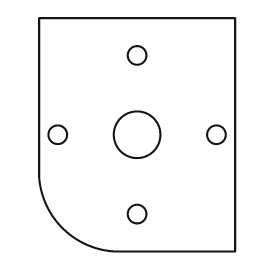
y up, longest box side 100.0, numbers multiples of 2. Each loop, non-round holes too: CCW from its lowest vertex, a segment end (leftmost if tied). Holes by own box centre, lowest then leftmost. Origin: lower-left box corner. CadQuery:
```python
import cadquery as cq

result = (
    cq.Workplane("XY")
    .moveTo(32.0, 0.0)
    .lineTo(84.0, 0.0)
    .lineTo(84.0, 100.0)
    .lineTo(0.0, 100.0)
    .lineTo(0.0, 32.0)
    .threePointArc((10.0, 10.0), (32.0, 0.0))
    .close()
    .moveTo(42.0, 16.0)
    .circle(4.0)
    .moveTo(8.0, 50.0)
    .circle(4.0)
    .moveTo(42.0, 50.0)
    .circle(10.0)
    .moveTo(76.0, 50.0)
    .circle(4.0)
    .moveTo(42.0, 84.0)
    .circle(4.0)
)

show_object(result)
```